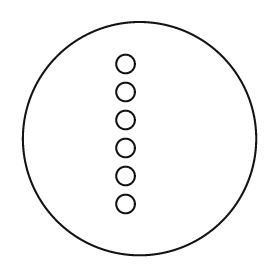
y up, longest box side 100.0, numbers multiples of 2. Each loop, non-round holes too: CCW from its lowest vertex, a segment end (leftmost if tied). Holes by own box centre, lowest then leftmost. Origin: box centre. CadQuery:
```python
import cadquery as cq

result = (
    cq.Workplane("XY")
    .moveTo(0.0, 0.0)
    .circle(50.0)
    .moveTo(-6.0, -28.0)
    .circle(4.0)
    .moveTo(-6.0, -16.0)
    .circle(4.0)
    .moveTo(-6.0, -4.0)
    .circle(4.0)
    .moveTo(-6.0, 8.0)
    .circle(4.0)
    .moveTo(-6.0, 20.0)
    .circle(4.0)
    .moveTo(-6.0, 32.0)
    .circle(4.0)
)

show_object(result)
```